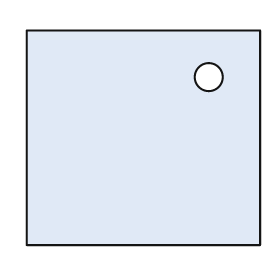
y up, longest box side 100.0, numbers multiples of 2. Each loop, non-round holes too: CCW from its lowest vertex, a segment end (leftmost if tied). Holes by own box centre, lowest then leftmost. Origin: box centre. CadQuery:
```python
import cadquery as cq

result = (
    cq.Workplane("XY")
    .moveTo(-50.0, -46.0)
    .lineTo(50.0, -46.0)
    .lineTo(50.0, 46.0)
    .lineTo(-50.0, 46.0)
    .close()
    .moveTo(28.0, 26.0)
    .circle(6.0)
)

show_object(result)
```